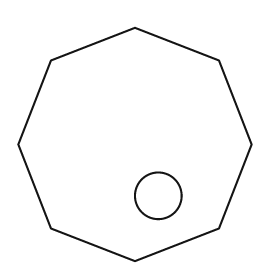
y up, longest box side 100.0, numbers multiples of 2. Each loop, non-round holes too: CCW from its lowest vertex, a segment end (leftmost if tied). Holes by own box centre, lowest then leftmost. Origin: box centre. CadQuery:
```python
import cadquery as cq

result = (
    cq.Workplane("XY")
    .moveTo(0.0, -50.0)
    .lineTo(36.0, -36.0)
    .lineTo(50.0, 0.0)
    .lineTo(36.0, 36.0)
    .lineTo(0.0, 50.0)
    .lineTo(-36.0, 36.0)
    .lineTo(-50.0, 0.0)
    .lineTo(-36.0, -36.0)
    .close()
    .moveTo(10.0, -22.0)
    .circle(10.0)
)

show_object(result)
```